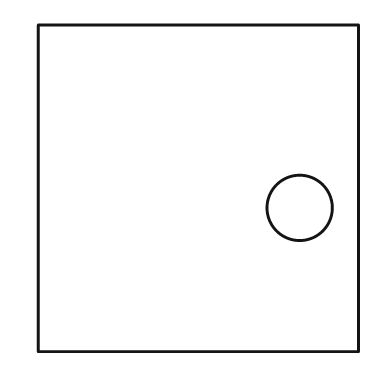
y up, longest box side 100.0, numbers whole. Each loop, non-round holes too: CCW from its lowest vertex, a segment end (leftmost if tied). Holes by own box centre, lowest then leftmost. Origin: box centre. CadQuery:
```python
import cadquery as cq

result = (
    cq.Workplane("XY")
    .moveTo(-49.0, -50.0)
    .lineTo(49.0, -50.0)
    .lineTo(49.0, 50.0)
    .lineTo(-49.0, 50.0)
    .close()
    .moveTo(31.0, -6.0)
    .circle(10.0)
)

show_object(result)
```